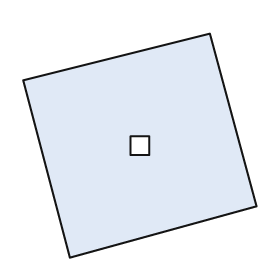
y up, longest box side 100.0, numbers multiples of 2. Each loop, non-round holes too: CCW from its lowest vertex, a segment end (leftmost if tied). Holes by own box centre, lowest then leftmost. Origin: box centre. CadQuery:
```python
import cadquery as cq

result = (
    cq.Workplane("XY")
    .moveTo(-30.0, -48.0)
    .lineTo(50.0, -26.0)
    .lineTo(30.0, 48.0)
    .lineTo(-50.0, 28.0)
    .close()
    .moveTo(-4.0, -4.0)
    .lineTo(4.0, -4.0)
    .lineTo(4.0, 4.0)
    .lineTo(-4.0, 4.0)
    .close()
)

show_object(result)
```